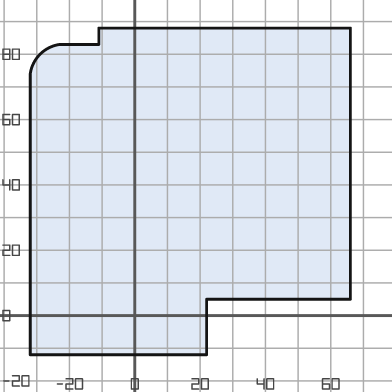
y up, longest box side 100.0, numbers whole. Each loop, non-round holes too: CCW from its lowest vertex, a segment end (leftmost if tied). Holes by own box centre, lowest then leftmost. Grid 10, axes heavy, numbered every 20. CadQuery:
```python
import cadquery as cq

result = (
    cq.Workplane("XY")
    .moveTo(-32.0, -12.0)
    .lineTo(22.0, -12.0)
    .lineTo(22.0, 5.0)
    .lineTo(66.0, 5.0)
    .lineTo(66.0, 88.0)
    .lineTo(-11.0, 88.0)
    .lineTo(-11.0, 83.0)
    .lineTo(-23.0, 83.0)
    .threePointArc((-29.0, 80.0), (-32.0, 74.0))
    .close()
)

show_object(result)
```